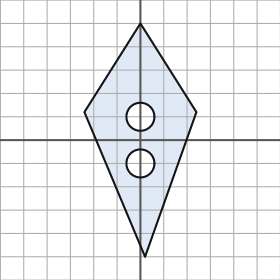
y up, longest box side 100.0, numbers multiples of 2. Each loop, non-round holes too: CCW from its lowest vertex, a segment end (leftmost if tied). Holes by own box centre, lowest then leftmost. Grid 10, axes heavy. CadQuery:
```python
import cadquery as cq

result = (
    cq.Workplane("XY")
    .moveTo(2.0, -50.0)
    .lineTo(24.0, 12.0)
    .lineTo(0.0, 50.0)
    .lineTo(-24.0, 12.0)
    .close()
    .moveTo(0.0, -10.0)
    .circle(6.0)
    .moveTo(0.0, 10.0)
    .circle(6.0)
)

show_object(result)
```